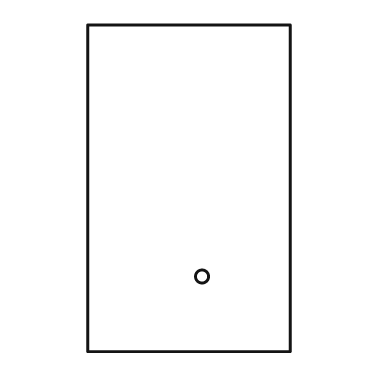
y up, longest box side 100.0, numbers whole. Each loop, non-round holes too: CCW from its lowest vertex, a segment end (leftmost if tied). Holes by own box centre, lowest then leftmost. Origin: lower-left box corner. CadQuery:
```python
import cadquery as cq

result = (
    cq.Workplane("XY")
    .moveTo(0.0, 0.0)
    .lineTo(62.0, 0.0)
    .lineTo(62.0, 100.0)
    .lineTo(0.0, 100.0)
    .close()
    .moveTo(35.0, 23.0)
    .circle(2.0)
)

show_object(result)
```